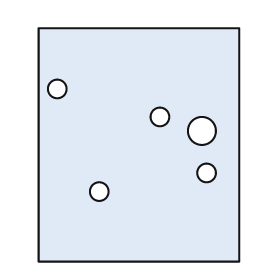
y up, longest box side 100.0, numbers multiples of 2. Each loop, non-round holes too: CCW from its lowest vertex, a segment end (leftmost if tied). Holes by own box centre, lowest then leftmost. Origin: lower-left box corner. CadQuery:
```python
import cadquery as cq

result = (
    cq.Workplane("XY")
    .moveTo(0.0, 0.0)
    .lineTo(86.0, 0.0)
    .lineTo(86.0, 100.0)
    .lineTo(0.0, 100.0)
    .close()
    .moveTo(26.0, 30.0)
    .circle(4.0)
    .moveTo(72.0, 38.0)
    .circle(4.0)
    .moveTo(70.0, 56.0)
    .circle(6.0)
    .moveTo(52.0, 62.0)
    .circle(4.0)
    .moveTo(8.0, 74.0)
    .circle(4.0)
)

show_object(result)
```